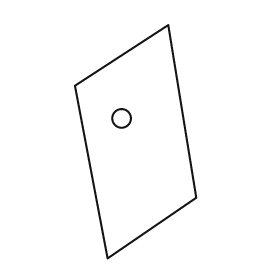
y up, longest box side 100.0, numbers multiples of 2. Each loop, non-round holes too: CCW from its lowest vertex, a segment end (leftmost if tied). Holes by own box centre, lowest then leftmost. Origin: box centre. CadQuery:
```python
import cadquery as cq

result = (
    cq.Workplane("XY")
    .moveTo(-12.0, -50.0)
    .lineTo(26.0, -24.0)
    .lineTo(14.0, 50.0)
    .lineTo(-26.0, 24.0)
    .close()
    .moveTo(-6.0, 10.0)
    .circle(4.0)
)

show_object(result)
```